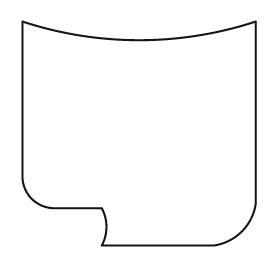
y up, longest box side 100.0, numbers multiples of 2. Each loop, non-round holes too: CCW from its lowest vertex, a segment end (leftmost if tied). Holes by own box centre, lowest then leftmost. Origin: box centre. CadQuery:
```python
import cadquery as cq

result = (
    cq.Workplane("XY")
    .moveTo(-16.0, -48.0)
    .lineTo(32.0, -48.0)
    .threePointArc((44.0, -42.0), (50.0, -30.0))
    .lineTo(50.0, 48.0)
    .threePointArc((0.0, 40.0), (-50.0, 48.0))
    .lineTo(-50.0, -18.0)
    .threePointArc((-46.0, -28.0), (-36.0, -32.0))
    .lineTo(-16.0, -32.0)
    .threePointArc((-14.0, -40.0), (-16.0, -48.0))
    .close()
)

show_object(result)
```